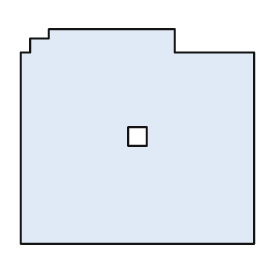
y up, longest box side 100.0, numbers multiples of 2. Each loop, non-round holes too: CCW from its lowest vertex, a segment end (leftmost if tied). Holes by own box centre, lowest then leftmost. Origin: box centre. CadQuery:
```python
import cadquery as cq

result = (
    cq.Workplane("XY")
    .moveTo(-50.0, -46.0)
    .lineTo(50.0, -46.0)
    .lineTo(50.0, 36.0)
    .lineTo(16.0, 36.0)
    .lineTo(16.0, 46.0)
    .lineTo(-38.0, 46.0)
    .lineTo(-38.0, 42.0)
    .lineTo(-46.0, 42.0)
    .lineTo(-46.0, 36.0)
    .lineTo(-50.0, 36.0)
    .close()
    .moveTo(-4.0, -4.0)
    .lineTo(4.0, -4.0)
    .lineTo(4.0, 4.0)
    .lineTo(-4.0, 4.0)
    .close()
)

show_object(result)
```